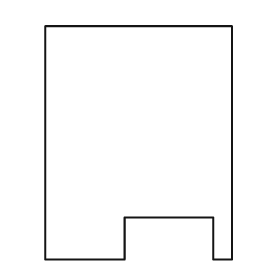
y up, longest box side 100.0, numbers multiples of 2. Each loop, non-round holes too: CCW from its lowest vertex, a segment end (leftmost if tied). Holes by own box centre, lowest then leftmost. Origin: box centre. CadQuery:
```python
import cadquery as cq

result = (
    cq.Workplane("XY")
    .moveTo(-40.0, -50.0)
    .lineTo(-6.0, -50.0)
    .lineTo(-6.0, -32.0)
    .lineTo(32.0, -32.0)
    .lineTo(32.0, -50.0)
    .lineTo(40.0, -50.0)
    .lineTo(40.0, 50.0)
    .lineTo(-40.0, 50.0)
    .close()
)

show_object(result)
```